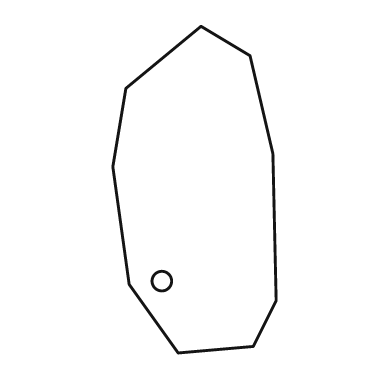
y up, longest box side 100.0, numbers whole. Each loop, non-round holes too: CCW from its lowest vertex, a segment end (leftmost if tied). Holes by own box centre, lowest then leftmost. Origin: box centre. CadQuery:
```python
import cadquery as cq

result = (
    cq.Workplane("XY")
    .moveTo(-5.0, -50.0)
    .lineTo(18.0, -48.0)
    .lineTo(25.0, -34.0)
    .lineTo(24.0, 11.0)
    .lineTo(17.0, 41.0)
    .lineTo(2.0, 50.0)
    .lineTo(-21.0, 31.0)
    .lineTo(-25.0, 7.0)
    .lineTo(-20.0, -29.0)
    .close()
    .moveTo(-10.0, -28.0)
    .circle(3.0)
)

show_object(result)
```